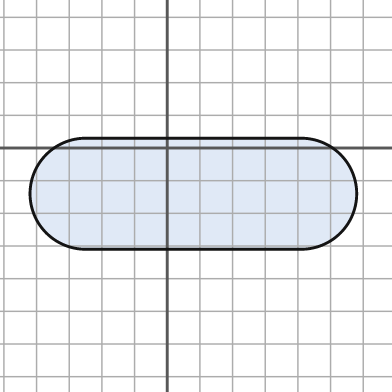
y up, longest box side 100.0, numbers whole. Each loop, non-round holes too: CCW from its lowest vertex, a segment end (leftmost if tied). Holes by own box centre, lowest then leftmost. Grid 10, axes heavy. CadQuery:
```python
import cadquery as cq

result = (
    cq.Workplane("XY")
    .moveTo(-25.0, -31.0)
    .lineTo(41.0, -31.0)
    .threePointArc((58.0, -14.0), (41.0, 3.0))
    .lineTo(-25.0, 3.0)
    .threePointArc((-42.0, -14.0), (-25.0, -31.0))
    .close()
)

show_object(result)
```